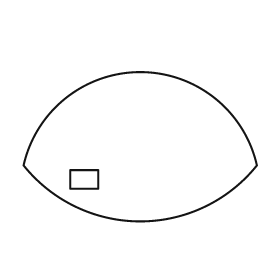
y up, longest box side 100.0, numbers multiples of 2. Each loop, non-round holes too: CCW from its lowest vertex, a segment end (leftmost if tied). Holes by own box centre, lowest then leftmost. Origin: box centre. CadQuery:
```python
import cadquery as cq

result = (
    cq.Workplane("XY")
    .moveTo(-50.0, -8.0)
    .threePointArc((0.0, -32.0), (50.0, -8.0))
    .threePointArc((0.0, 32.0), (-50.0, -8.0))
    .close()
    .moveTo(-30.0, -18.0)
    .lineTo(-18.0, -18.0)
    .lineTo(-18.0, -10.0)
    .lineTo(-30.0, -10.0)
    .close()
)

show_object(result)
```